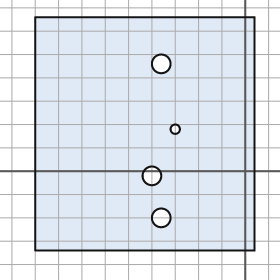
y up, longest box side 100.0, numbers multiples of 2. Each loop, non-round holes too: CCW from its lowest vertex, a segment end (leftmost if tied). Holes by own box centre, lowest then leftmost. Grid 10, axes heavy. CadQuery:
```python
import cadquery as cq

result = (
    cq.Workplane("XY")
    .moveTo(-90.0, -34.0)
    .lineTo(4.0, -34.0)
    .lineTo(4.0, 66.0)
    .lineTo(-90.0, 66.0)
    .close()
    .moveTo(-36.0, -20.0)
    .circle(4.0)
    .moveTo(-40.0, -2.0)
    .circle(4.0)
    .moveTo(-30.0, 18.0)
    .circle(2.0)
    .moveTo(-36.0, 46.0)
    .circle(4.0)
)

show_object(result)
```